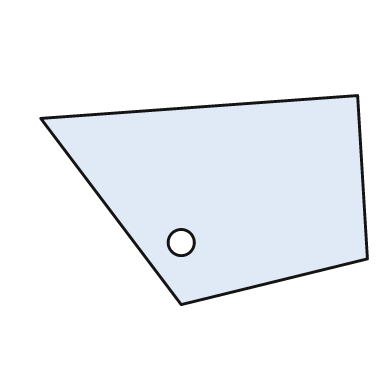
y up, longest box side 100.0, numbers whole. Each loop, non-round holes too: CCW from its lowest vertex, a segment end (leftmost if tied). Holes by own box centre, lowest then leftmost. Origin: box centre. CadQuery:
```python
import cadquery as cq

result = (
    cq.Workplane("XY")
    .moveTo(-7.0, -32.0)
    .lineTo(50.0, -18.0)
    .lineTo(47.0, 32.0)
    .lineTo(-50.0, 25.0)
    .close()
    .moveTo(-7.0, -13.0)
    .circle(4.0)
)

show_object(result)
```